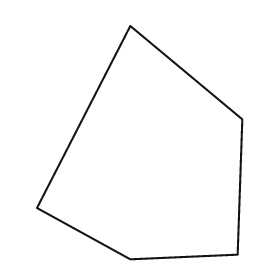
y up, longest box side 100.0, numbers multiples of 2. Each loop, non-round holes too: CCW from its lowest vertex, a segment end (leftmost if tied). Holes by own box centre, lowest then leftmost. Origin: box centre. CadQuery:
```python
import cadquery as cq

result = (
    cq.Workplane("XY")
    .moveTo(-4.0, -50.0)
    .lineTo(42.0, -48.0)
    .lineTo(44.0, 10.0)
    .lineTo(-4.0, 50.0)
    .lineTo(-44.0, -28.0)
    .close()
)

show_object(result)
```